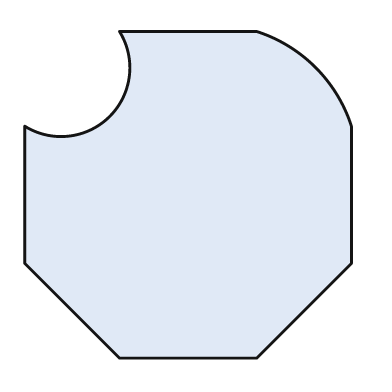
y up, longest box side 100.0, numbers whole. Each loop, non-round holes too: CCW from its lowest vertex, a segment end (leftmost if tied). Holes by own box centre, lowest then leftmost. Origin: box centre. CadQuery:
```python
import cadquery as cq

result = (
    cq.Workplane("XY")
    .moveTo(-21.0, -50.0)
    .lineTo(21.0, -50.0)
    .lineTo(50.0, -21.0)
    .lineTo(50.0, 21.0)
    .threePointArc((39.0, 39.0), (21.0, 50.0))
    .lineTo(-21.0, 50.0)
    .threePointArc((-24.0, 24.0), (-50.0, 21.0))
    .lineTo(-50.0, -21.0)
    .close()
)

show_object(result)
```